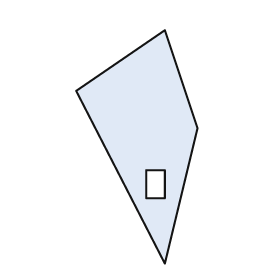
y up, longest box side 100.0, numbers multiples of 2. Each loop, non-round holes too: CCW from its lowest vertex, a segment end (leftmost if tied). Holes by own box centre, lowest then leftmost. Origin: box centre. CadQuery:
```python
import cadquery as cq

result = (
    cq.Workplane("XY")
    .moveTo(12.0, -50.0)
    .lineTo(26.0, 8.0)
    .lineTo(12.0, 50.0)
    .lineTo(-26.0, 24.0)
    .close()
    .moveTo(4.0, -22.0)
    .lineTo(12.0, -22.0)
    .lineTo(12.0, -10.0)
    .lineTo(4.0, -10.0)
    .close()
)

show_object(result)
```